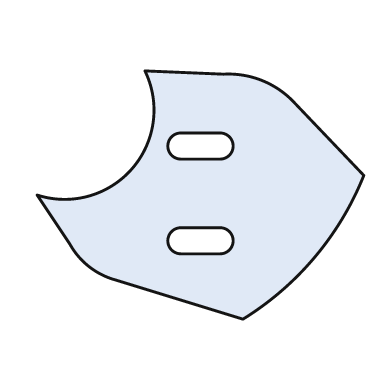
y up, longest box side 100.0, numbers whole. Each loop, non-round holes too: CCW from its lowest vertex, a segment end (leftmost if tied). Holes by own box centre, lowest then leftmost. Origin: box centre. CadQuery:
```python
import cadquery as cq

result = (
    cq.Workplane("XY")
    .moveTo(13.0, -38.0)
    .threePointArc((35.0, -19.0), (50.0, 6.0))
    .lineTo(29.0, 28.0)
    .threePointArc((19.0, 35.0), (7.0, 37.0))
    .lineTo(-17.0, 38.0)
    .threePointArc((-21.0, 8.0), (-50.0, 0.0))
    .lineTo(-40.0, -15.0)
    .threePointArc((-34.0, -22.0), (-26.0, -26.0))
    .close()
    .moveTo(-6.0, -18.0)
    .lineTo(6.0, -18.0)
    .threePointArc((10.0, -14.0), (6.0, -10.0))
    .lineTo(-6.0, -10.0)
    .threePointArc((-10.0, -14.0), (-6.0, -18.0))
    .close()
    .moveTo(-6.0, 11.0)
    .lineTo(6.0, 11.0)
    .threePointArc((10.0, 15.0), (6.0, 19.0))
    .lineTo(-6.0, 19.0)
    .threePointArc((-10.0, 15.0), (-6.0, 11.0))
    .close()
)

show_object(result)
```